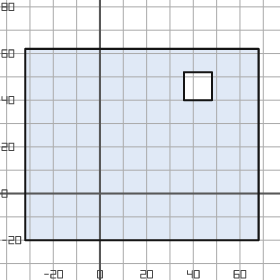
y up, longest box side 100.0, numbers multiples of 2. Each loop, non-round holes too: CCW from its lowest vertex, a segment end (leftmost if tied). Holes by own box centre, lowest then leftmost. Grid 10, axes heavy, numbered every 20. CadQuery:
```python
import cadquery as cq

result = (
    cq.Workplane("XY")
    .moveTo(-32.0, -20.0)
    .lineTo(68.0, -20.0)
    .lineTo(68.0, 62.0)
    .lineTo(-32.0, 62.0)
    .close()
    .moveTo(36.0, 40.0)
    .lineTo(48.0, 40.0)
    .lineTo(48.0, 52.0)
    .lineTo(36.0, 52.0)
    .close()
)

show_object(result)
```